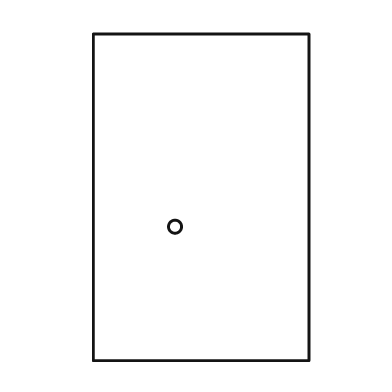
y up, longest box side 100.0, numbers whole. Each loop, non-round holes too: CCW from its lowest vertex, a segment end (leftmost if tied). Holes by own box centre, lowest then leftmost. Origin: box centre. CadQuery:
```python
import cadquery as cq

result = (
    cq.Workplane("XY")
    .moveTo(-33.0, -50.0)
    .lineTo(33.0, -50.0)
    .lineTo(33.0, 50.0)
    .lineTo(-33.0, 50.0)
    .close()
    .moveTo(-8.0, -9.0)
    .circle(2.0)
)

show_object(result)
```